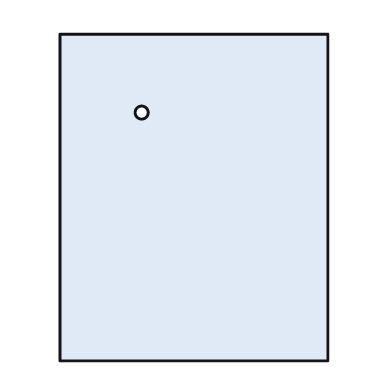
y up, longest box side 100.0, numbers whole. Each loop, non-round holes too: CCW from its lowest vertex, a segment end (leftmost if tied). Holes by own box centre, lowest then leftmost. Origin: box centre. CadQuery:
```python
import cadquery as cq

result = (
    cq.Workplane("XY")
    .moveTo(-41.0, -50.0)
    .lineTo(41.0, -50.0)
    .lineTo(41.0, 50.0)
    .lineTo(-41.0, 50.0)
    .close()
    .moveTo(-16.0, 26.0)
    .circle(2.0)
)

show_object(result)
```